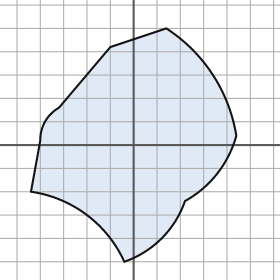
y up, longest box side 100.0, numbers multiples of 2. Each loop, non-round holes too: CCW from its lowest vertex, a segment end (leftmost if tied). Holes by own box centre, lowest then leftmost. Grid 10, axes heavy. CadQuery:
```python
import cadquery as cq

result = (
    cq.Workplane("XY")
    .moveTo(-4.0, -50.0)
    .threePointArc((12.0, -40.0), (22.0, -24.0))
    .threePointArc((36.0, -12.0), (44.0, 4.0))
    .threePointArc((34.0, 30.0), (14.0, 50.0))
    .lineTo(-10.0, 42.0)
    .lineTo(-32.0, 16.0)
    .threePointArc((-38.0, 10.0), (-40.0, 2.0))
    .lineTo(-44.0, -20.0)
    .threePointArc((-20.0, -30.0), (-4.0, -50.0))
    .close()
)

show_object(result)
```